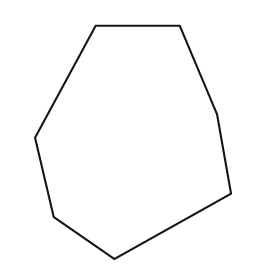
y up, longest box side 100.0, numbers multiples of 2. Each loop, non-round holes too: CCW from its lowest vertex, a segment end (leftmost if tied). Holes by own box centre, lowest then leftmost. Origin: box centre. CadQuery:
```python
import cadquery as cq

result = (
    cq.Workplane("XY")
    .moveTo(-8.0, -50.0)
    .lineTo(42.0, -22.0)
    .lineTo(36.0, 12.0)
    .lineTo(20.0, 50.0)
    .lineTo(-16.0, 50.0)
    .lineTo(-42.0, 2.0)
    .lineTo(-34.0, -32.0)
    .close()
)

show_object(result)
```